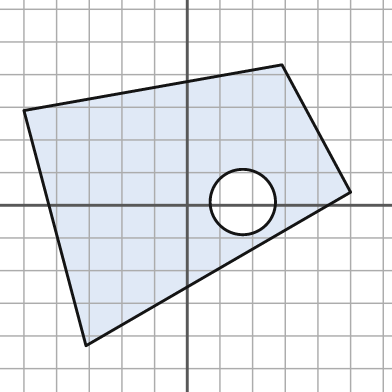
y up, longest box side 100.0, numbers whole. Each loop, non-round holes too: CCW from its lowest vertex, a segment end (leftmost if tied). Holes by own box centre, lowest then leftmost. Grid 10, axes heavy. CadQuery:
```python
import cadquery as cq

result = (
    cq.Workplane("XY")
    .moveTo(-31.0, -43.0)
    .lineTo(50.0, 4.0)
    .lineTo(29.0, 43.0)
    .lineTo(-50.0, 29.0)
    .close()
    .moveTo(17.0, 1.0)
    .circle(10.0)
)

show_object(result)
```